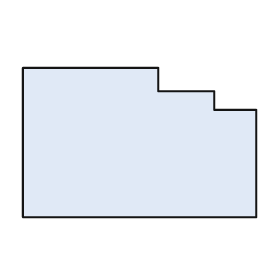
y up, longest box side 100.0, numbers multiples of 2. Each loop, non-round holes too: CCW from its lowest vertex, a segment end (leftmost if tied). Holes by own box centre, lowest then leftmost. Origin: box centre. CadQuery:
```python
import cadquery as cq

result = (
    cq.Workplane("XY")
    .moveTo(-50.0, -32.0)
    .lineTo(50.0, -32.0)
    .lineTo(50.0, 14.0)
    .lineTo(32.0, 14.0)
    .lineTo(32.0, 22.0)
    .lineTo(8.0, 22.0)
    .lineTo(8.0, 32.0)
    .lineTo(-50.0, 32.0)
    .close()
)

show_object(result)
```